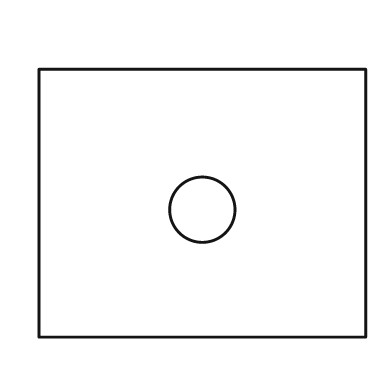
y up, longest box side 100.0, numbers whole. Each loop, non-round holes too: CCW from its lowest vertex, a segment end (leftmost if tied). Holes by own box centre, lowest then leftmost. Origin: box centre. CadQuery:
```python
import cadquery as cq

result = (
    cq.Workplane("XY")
    .moveTo(-50.0, -41.0)
    .lineTo(50.0, -41.0)
    .lineTo(50.0, 41.0)
    .lineTo(-50.0, 41.0)
    .close()
    .moveTo(0.0, -2.0)
    .circle(10.0)
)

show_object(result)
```